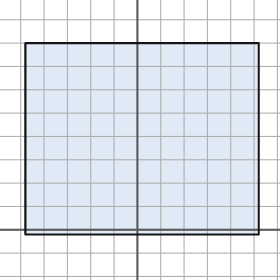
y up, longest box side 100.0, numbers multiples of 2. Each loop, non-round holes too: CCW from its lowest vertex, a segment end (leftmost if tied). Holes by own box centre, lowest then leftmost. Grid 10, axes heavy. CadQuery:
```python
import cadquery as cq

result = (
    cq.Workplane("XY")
    .moveTo(-48.0, -2.0)
    .lineTo(52.0, -2.0)
    .lineTo(52.0, 80.0)
    .lineTo(-48.0, 80.0)
    .close()
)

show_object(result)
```